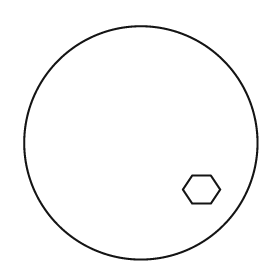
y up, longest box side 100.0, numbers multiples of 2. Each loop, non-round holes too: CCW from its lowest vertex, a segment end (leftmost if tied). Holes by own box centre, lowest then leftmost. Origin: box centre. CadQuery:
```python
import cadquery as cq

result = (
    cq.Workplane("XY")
    .moveTo(0.0, 0.0)
    .circle(50.0)
    .moveTo(22.0, -26.0)
    .lineTo(30.0, -26.0)
    .lineTo(34.0, -20.0)
    .lineTo(30.0, -14.0)
    .lineTo(22.0, -14.0)
    .lineTo(18.0, -20.0)
    .close()
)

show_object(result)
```